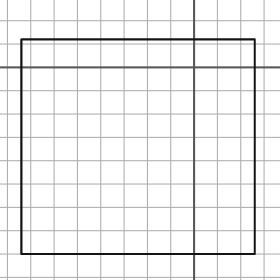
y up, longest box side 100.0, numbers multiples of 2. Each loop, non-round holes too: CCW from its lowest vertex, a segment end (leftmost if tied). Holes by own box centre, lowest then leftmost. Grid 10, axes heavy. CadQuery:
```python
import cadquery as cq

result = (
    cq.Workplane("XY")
    .moveTo(-74.0, -80.0)
    .lineTo(26.0, -80.0)
    .lineTo(26.0, 12.0)
    .lineTo(-74.0, 12.0)
    .close()
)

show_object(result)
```